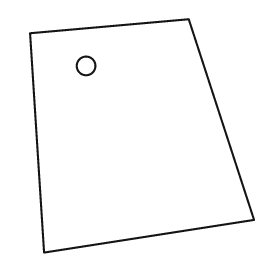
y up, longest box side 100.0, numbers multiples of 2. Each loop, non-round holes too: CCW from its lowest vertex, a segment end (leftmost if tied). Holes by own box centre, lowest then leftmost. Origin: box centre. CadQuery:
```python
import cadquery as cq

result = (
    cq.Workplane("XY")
    .moveTo(-42.0, -50.0)
    .lineTo(48.0, -36.0)
    .lineTo(20.0, 50.0)
    .lineTo(-48.0, 44.0)
    .close()
    .moveTo(-24.0, 30.0)
    .circle(4.0)
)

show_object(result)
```